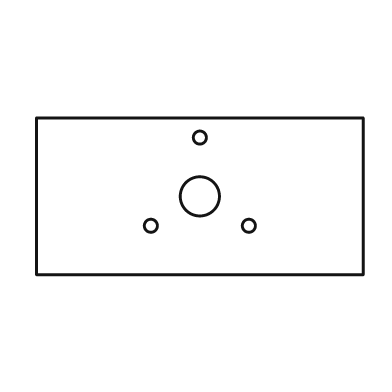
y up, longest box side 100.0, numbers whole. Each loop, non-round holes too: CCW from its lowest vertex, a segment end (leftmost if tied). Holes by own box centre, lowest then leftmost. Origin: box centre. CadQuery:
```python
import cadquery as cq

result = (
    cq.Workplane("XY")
    .moveTo(-50.0, -24.0)
    .lineTo(50.0, -24.0)
    .lineTo(50.0, 24.0)
    .lineTo(-50.0, 24.0)
    .close()
    .moveTo(-15.0, -9.0)
    .circle(2.0)
    .moveTo(15.0, -9.0)
    .circle(2.0)
    .moveTo(0.0, 0.0)
    .circle(6.0)
    .moveTo(0.0, 18.0)
    .circle(2.0)
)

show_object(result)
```